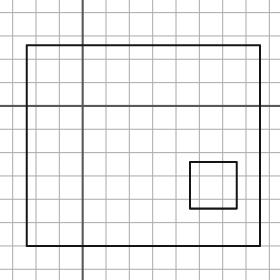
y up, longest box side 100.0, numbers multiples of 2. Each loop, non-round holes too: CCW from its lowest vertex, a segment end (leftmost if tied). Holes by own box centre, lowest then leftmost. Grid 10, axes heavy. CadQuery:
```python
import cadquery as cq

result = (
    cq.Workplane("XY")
    .moveTo(-24.0, -60.0)
    .lineTo(76.0, -60.0)
    .lineTo(76.0, 26.0)
    .lineTo(-24.0, 26.0)
    .close()
    .moveTo(46.0, -44.0)
    .lineTo(66.0, -44.0)
    .lineTo(66.0, -24.0)
    .lineTo(46.0, -24.0)
    .close()
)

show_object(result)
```